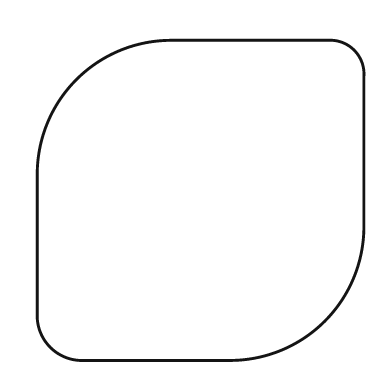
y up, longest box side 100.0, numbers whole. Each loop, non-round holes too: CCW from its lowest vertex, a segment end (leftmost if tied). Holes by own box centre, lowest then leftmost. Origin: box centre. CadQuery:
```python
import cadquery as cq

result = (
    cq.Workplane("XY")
    .moveTo(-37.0, -49.0)
    .lineTo(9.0, -49.0)
    .threePointArc((38.0, -37.0), (50.0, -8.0))
    .lineTo(50.0, 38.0)
    .threePointArc((47.0, 46.0), (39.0, 49.0))
    .lineTo(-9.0, 49.0)
    .threePointArc((-38.0, 37.0), (-50.0, 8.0))
    .lineTo(-50.0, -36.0)
    .threePointArc((-46.0, -45.0), (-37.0, -49.0))
    .close()
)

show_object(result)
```